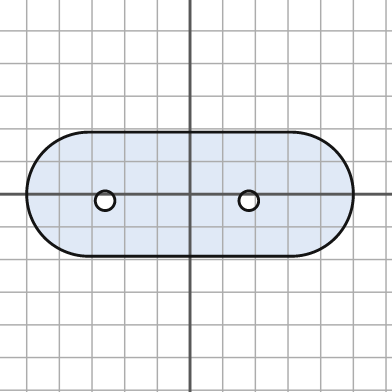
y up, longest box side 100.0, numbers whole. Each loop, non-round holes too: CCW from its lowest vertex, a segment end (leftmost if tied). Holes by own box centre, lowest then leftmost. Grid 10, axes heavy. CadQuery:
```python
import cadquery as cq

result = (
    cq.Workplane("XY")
    .moveTo(-31.0, -19.0)
    .lineTo(31.0, -19.0)
    .threePointArc((50.0, 0.0), (31.0, 19.0))
    .lineTo(-31.0, 19.0)
    .threePointArc((-50.0, 0.0), (-31.0, -19.0))
    .close()
    .moveTo(-26.0, -2.0)
    .circle(3.0)
    .moveTo(18.0, -2.0)
    .circle(3.0)
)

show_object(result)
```